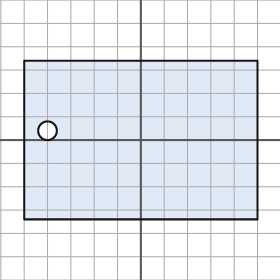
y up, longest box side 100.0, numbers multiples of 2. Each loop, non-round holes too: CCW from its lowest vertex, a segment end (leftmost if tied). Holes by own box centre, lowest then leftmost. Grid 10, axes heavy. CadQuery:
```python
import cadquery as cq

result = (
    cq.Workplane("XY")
    .moveTo(-50.0, -34.0)
    .lineTo(50.0, -34.0)
    .lineTo(50.0, 34.0)
    .lineTo(-50.0, 34.0)
    .close()
    .moveTo(-40.0, 4.0)
    .circle(4.0)
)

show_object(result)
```